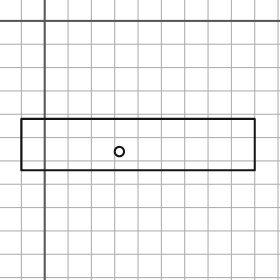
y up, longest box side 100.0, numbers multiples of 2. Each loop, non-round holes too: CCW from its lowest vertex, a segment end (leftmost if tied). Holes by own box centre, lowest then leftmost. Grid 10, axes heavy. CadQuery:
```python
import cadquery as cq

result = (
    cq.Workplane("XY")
    .moveTo(-10.0, -64.0)
    .lineTo(90.0, -64.0)
    .lineTo(90.0, -42.0)
    .lineTo(-10.0, -42.0)
    .close()
    .moveTo(32.0, -56.0)
    .circle(2.0)
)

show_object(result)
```